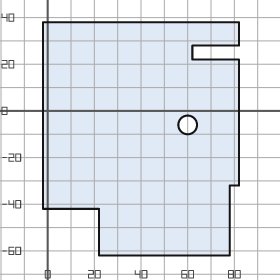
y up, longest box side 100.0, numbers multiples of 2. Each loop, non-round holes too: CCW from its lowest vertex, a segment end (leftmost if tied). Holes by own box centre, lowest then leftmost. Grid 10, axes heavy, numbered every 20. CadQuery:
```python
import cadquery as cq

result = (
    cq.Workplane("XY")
    .moveTo(22.0, -62.0)
    .lineTo(78.0, -62.0)
    .lineTo(78.0, -32.0)
    .lineTo(82.0, -32.0)
    .lineTo(82.0, 22.0)
    .lineTo(62.0, 22.0)
    .lineTo(62.0, 28.0)
    .lineTo(82.0, 28.0)
    .lineTo(82.0, 38.0)
    .lineTo(-2.0, 38.0)
    .lineTo(-2.0, -42.0)
    .lineTo(22.0, -42.0)
    .close()
    .moveTo(60.0, -6.0)
    .circle(4.0)
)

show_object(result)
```